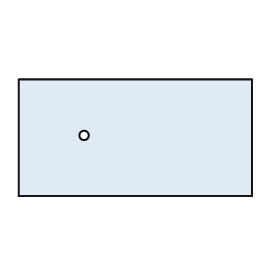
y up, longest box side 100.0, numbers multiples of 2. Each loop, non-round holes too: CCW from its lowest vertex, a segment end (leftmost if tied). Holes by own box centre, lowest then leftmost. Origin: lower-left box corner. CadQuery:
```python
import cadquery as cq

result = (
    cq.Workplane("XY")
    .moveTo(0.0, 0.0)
    .lineTo(100.0, 0.0)
    .lineTo(100.0, 50.0)
    .lineTo(0.0, 50.0)
    .close()
    .moveTo(28.0, 26.0)
    .circle(2.0)
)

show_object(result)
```